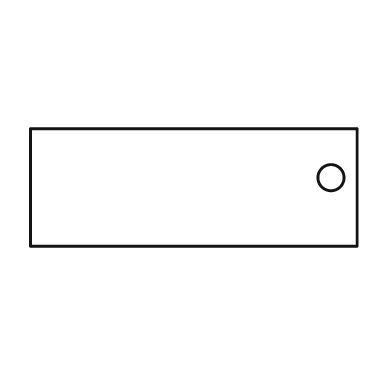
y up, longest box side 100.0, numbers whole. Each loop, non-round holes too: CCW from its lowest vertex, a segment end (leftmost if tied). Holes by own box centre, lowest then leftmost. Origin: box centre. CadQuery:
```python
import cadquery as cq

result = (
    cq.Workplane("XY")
    .moveTo(-50.0, -18.0)
    .lineTo(50.0, -18.0)
    .lineTo(50.0, 18.0)
    .lineTo(-50.0, 18.0)
    .close()
    .moveTo(42.0, 3.0)
    .circle(4.0)
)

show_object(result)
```